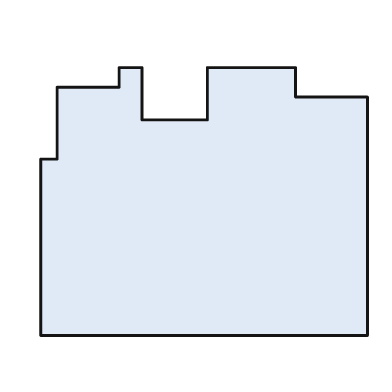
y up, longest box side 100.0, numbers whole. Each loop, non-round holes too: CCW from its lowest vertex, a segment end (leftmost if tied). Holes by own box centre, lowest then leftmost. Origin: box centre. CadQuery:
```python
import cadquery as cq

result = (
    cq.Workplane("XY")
    .moveTo(-50.0, -41.0)
    .lineTo(50.0, -41.0)
    .lineTo(50.0, 32.0)
    .lineTo(28.0, 32.0)
    .lineTo(28.0, 41.0)
    .lineTo(1.0, 41.0)
    .lineTo(1.0, 25.0)
    .lineTo(-19.0, 25.0)
    .lineTo(-19.0, 41.0)
    .lineTo(-26.0, 41.0)
    .lineTo(-26.0, 35.0)
    .lineTo(-45.0, 35.0)
    .lineTo(-45.0, 13.0)
    .lineTo(-50.0, 13.0)
    .close()
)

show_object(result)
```